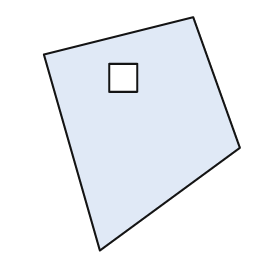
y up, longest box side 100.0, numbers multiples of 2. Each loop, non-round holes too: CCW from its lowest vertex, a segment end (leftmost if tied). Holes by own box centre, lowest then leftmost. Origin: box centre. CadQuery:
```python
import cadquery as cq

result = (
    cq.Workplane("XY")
    .moveTo(-18.0, -50.0)
    .lineTo(42.0, -6.0)
    .lineTo(22.0, 50.0)
    .lineTo(-42.0, 34.0)
    .close()
    .moveTo(-14.0, 18.0)
    .lineTo(-2.0, 18.0)
    .lineTo(-2.0, 30.0)
    .lineTo(-14.0, 30.0)
    .close()
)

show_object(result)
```